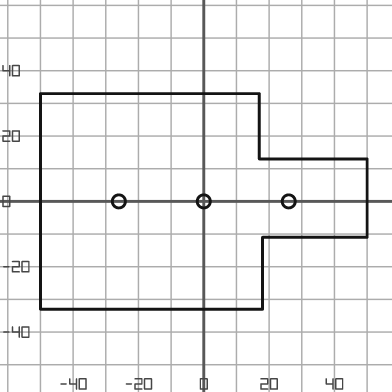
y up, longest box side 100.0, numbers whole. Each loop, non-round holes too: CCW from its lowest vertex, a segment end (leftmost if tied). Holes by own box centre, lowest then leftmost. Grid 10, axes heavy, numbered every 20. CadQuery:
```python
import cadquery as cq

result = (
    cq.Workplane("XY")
    .moveTo(-50.0, -33.0)
    .lineTo(18.0, -33.0)
    .lineTo(18.0, -11.0)
    .lineTo(50.0, -11.0)
    .lineTo(50.0, 13.0)
    .lineTo(17.0, 13.0)
    .lineTo(17.0, 33.0)
    .lineTo(-50.0, 33.0)
    .close()
    .moveTo(-26.0, 0.0)
    .circle(2.0)
    .moveTo(0.0, 0.0)
    .circle(2.0)
    .moveTo(26.0, 0.0)
    .circle(2.0)
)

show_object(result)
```